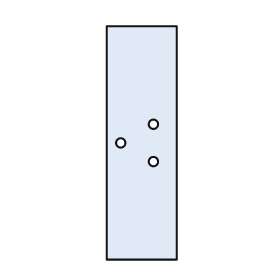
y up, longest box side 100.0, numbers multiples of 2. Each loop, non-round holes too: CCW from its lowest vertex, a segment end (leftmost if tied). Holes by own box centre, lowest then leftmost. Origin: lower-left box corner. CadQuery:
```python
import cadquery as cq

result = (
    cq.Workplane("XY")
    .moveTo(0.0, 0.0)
    .lineTo(30.0, 0.0)
    .lineTo(30.0, 100.0)
    .lineTo(0.0, 100.0)
    .close()
    .moveTo(20.0, 42.0)
    .circle(2.0)
    .moveTo(6.0, 50.0)
    .circle(2.0)
    .moveTo(20.0, 58.0)
    .circle(2.0)
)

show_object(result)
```